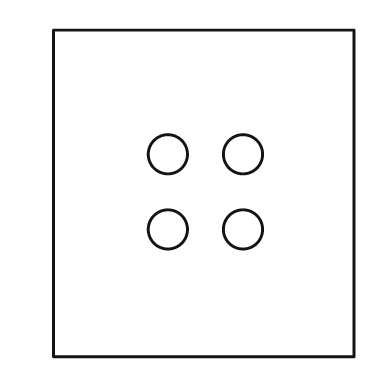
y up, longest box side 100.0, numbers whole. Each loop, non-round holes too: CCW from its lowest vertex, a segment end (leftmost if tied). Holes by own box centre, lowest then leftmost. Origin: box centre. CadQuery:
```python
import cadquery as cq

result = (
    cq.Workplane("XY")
    .moveTo(-46.0, -50.0)
    .lineTo(46.0, -50.0)
    .lineTo(46.0, 50.0)
    .lineTo(-46.0, 50.0)
    .close()
    .moveTo(-11.0, -11.0)
    .circle(6.0)
    .moveTo(12.0, -11.0)
    .circle(6.0)
    .moveTo(-11.0, 12.0)
    .circle(6.0)
    .moveTo(12.0, 12.0)
    .circle(6.0)
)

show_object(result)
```